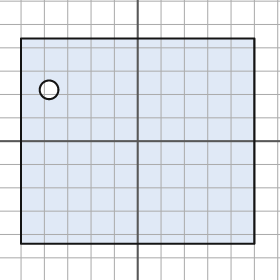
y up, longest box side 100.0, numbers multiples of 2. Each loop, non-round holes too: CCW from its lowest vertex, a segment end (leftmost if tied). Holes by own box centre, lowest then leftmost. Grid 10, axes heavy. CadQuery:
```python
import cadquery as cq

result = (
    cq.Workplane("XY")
    .moveTo(-50.0, -44.0)
    .lineTo(50.0, -44.0)
    .lineTo(50.0, 44.0)
    .lineTo(-50.0, 44.0)
    .close()
    .moveTo(-38.0, 22.0)
    .circle(4.0)
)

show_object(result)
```